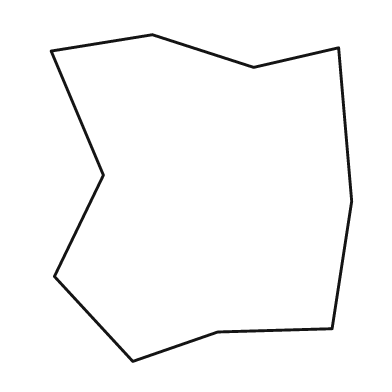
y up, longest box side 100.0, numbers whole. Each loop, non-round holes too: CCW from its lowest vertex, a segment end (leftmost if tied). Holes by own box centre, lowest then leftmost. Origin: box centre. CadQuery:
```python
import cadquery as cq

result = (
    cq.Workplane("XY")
    .moveTo(-21.0, -50.0)
    .lineTo(5.0, -41.0)
    .lineTo(40.0, -40.0)
    .lineTo(46.0, -1.0)
    .lineTo(42.0, 46.0)
    .lineTo(16.0, 40.0)
    .lineTo(-15.0, 50.0)
    .lineTo(-46.0, 45.0)
    .lineTo(-30.0, 7.0)
    .lineTo(-45.0, -24.0)
    .close()
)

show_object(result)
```